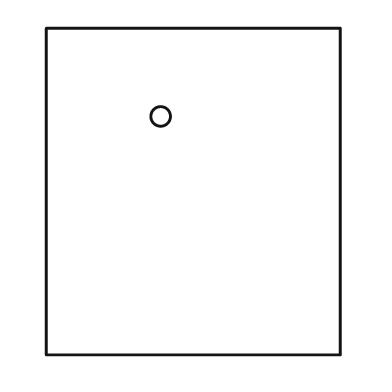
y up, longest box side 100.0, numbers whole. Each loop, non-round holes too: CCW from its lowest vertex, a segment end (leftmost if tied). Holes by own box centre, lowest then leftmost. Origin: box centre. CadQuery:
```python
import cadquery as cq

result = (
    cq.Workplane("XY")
    .moveTo(-45.0, -50.0)
    .lineTo(45.0, -50.0)
    .lineTo(45.0, 50.0)
    .lineTo(-45.0, 50.0)
    .close()
    .moveTo(-10.0, 23.0)
    .circle(3.0)
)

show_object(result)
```